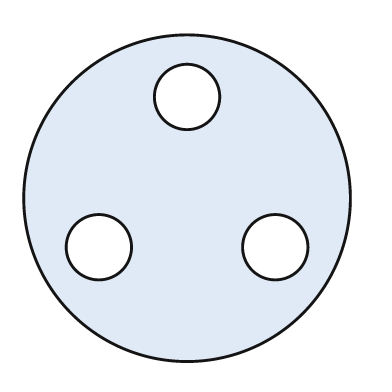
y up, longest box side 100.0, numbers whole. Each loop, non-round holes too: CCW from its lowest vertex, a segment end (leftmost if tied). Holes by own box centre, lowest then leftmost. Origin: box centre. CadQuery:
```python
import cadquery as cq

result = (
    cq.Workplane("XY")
    .moveTo(0.0, 0.0)
    .circle(50.0)
    .moveTo(-27.0, -15.0)
    .circle(10.0)
    .moveTo(27.0, -15.0)
    .circle(10.0)
    .moveTo(0.0, 31.0)
    .circle(10.0)
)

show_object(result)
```